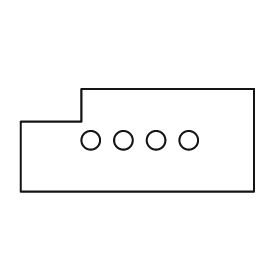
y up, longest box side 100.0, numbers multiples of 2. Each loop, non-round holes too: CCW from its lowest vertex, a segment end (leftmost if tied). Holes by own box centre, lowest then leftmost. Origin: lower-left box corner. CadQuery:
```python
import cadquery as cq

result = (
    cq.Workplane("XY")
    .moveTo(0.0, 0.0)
    .lineTo(100.0, 0.0)
    .lineTo(100.0, 44.0)
    .lineTo(26.0, 44.0)
    .lineTo(26.0, 30.0)
    .lineTo(0.0, 30.0)
    .close()
    .moveTo(30.0, 22.0)
    .circle(4.0)
    .moveTo(44.0, 22.0)
    .circle(4.0)
    .moveTo(58.0, 22.0)
    .circle(4.0)
    .moveTo(72.0, 22.0)
    .circle(4.0)
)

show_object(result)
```